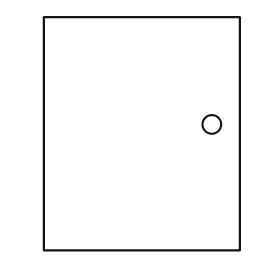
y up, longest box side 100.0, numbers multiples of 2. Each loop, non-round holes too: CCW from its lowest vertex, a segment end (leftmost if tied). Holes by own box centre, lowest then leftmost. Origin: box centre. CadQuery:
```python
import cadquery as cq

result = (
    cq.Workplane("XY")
    .moveTo(-42.0, -50.0)
    .lineTo(42.0, -50.0)
    .lineTo(42.0, 50.0)
    .lineTo(-42.0, 50.0)
    .close()
    .moveTo(30.0, 4.0)
    .circle(4.0)
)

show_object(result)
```